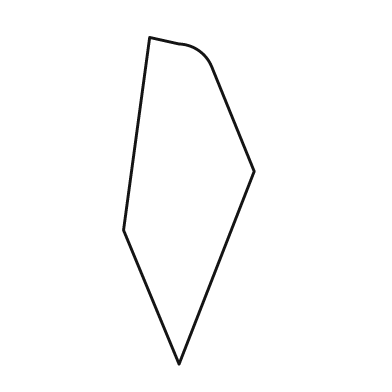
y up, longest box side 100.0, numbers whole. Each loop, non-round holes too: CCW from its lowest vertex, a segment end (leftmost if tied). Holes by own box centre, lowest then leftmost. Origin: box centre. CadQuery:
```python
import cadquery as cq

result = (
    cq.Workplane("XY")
    .moveTo(-3.0, -50.0)
    .lineTo(20.0, 9.0)
    .lineTo(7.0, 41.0)
    .threePointArc((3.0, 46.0), (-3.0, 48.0))
    .lineTo(-12.0, 50.0)
    .lineTo(-20.0, -9.0)
    .close()
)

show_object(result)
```